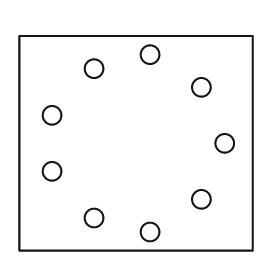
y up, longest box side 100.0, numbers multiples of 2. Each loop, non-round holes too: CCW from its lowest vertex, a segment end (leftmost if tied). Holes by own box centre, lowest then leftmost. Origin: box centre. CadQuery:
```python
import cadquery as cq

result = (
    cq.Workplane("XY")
    .moveTo(-50.0, -46.0)
    .lineTo(50.0, -46.0)
    .lineTo(50.0, 46.0)
    .lineTo(-50.0, 46.0)
    .close()
    .moveTo(6.0, -38.0)
    .circle(4.0)
    .moveTo(-18.0, -32.0)
    .circle(4.0)
    .moveTo(28.0, -24.0)
    .circle(4.0)
    .moveTo(-36.0, -12.0)
    .circle(4.0)
    .moveTo(38.0, 0.0)
    .circle(4.0)
    .moveTo(-36.0, 12.0)
    .circle(4.0)
    .moveTo(28.0, 24.0)
    .circle(4.0)
    .moveTo(-18.0, 32.0)
    .circle(4.0)
    .moveTo(6.0, 38.0)
    .circle(4.0)
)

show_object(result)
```